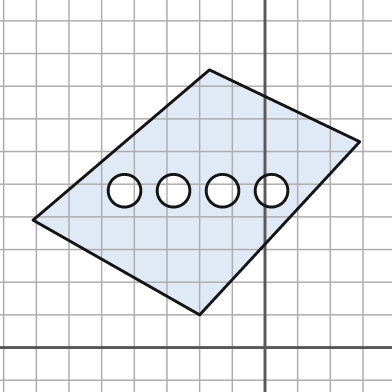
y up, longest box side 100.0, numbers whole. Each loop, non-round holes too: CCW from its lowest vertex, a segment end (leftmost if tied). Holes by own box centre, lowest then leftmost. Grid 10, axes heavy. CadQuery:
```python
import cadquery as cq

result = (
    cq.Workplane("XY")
    .moveTo(-20.0, 10.0)
    .lineTo(29.0, 63.0)
    .lineTo(-17.0, 85.0)
    .lineTo(-71.0, 39.0)
    .close()
    .moveTo(-43.0, 48.0)
    .circle(5.0)
    .moveTo(-28.0, 48.0)
    .circle(5.0)
    .moveTo(-13.0, 48.0)
    .circle(5.0)
    .moveTo(2.0, 48.0)
    .circle(5.0)
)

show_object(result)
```